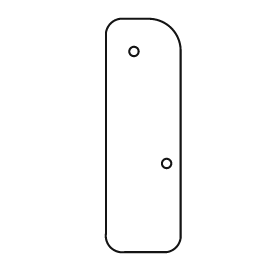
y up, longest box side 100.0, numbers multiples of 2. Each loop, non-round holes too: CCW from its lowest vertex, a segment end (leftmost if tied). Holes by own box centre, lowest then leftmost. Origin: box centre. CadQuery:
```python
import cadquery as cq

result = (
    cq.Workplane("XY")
    .moveTo(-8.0, -50.0)
    .lineTo(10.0, -50.0)
    .threePointArc((14.0, -48.0), (16.0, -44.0))
    .lineTo(16.0, 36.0)
    .threePointArc((12.0, 46.0), (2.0, 50.0))
    .lineTo(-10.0, 50.0)
    .threePointArc((-14.0, 48.0), (-16.0, 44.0))
    .lineTo(-16.0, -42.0)
    .threePointArc((-14.0, -48.0), (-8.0, -50.0))
    .close()
    .moveTo(10.0, -12.0)
    .circle(2.0)
    .moveTo(-4.0, 36.0)
    .circle(2.0)
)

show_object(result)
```